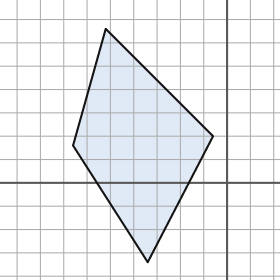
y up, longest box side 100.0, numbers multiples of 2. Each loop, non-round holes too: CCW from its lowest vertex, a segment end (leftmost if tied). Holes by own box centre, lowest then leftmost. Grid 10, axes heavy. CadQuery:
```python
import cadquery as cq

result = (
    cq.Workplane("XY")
    .moveTo(-34.0, -34.0)
    .lineTo(-6.0, 20.0)
    .lineTo(-52.0, 66.0)
    .lineTo(-66.0, 16.0)
    .close()
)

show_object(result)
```